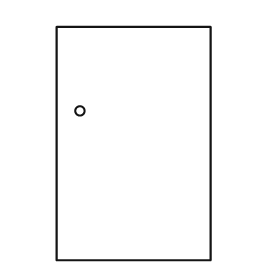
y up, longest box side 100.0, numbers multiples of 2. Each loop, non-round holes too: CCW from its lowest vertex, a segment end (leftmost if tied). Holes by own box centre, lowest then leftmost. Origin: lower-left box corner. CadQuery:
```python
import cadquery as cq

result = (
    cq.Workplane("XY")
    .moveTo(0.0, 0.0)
    .lineTo(66.0, 0.0)
    .lineTo(66.0, 100.0)
    .lineTo(0.0, 100.0)
    .close()
    .moveTo(10.0, 64.0)
    .circle(2.0)
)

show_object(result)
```